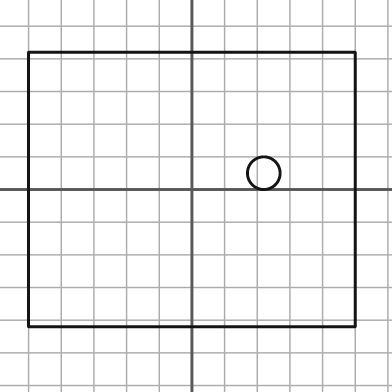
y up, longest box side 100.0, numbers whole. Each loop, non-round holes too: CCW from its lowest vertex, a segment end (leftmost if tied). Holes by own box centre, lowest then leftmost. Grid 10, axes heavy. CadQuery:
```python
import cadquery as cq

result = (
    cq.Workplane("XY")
    .moveTo(-50.0, -42.0)
    .lineTo(50.0, -42.0)
    .lineTo(50.0, 42.0)
    .lineTo(-50.0, 42.0)
    .close()
    .moveTo(22.0, 5.0)
    .circle(5.0)
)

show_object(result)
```